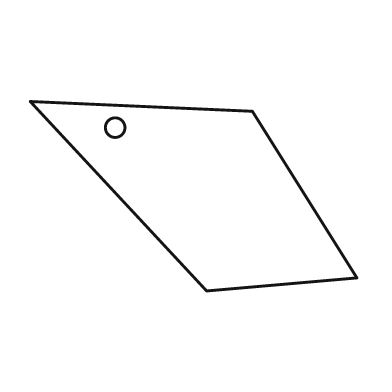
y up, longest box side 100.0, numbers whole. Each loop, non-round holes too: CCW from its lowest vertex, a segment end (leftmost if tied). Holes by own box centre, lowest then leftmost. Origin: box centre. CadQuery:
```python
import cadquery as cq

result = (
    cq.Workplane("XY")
    .moveTo(4.0, -29.0)
    .lineTo(50.0, -25.0)
    .lineTo(18.0, 26.0)
    .lineTo(-50.0, 29.0)
    .close()
    .moveTo(-24.0, 21.0)
    .circle(3.0)
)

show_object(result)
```